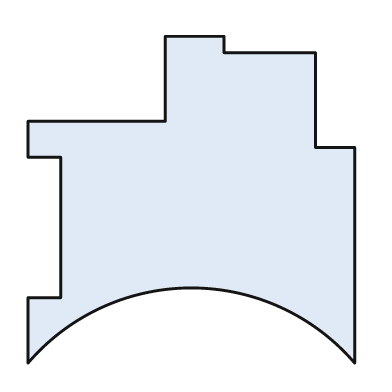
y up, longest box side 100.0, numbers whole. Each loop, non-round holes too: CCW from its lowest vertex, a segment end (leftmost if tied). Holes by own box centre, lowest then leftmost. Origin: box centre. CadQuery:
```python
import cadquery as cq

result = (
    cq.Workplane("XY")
    .moveTo(-50.0, -50.0)
    .threePointArc((0.0, -27.0), (50.0, -50.0))
    .lineTo(50.0, 16.0)
    .lineTo(38.0, 16.0)
    .lineTo(38.0, 45.0)
    .lineTo(10.0, 45.0)
    .lineTo(10.0, 50.0)
    .lineTo(-8.0, 50.0)
    .lineTo(-8.0, 24.0)
    .lineTo(-50.0, 24.0)
    .lineTo(-50.0, 13.0)
    .lineTo(-40.0, 13.0)
    .lineTo(-40.0, -30.0)
    .lineTo(-50.0, -30.0)
    .close()
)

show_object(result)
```